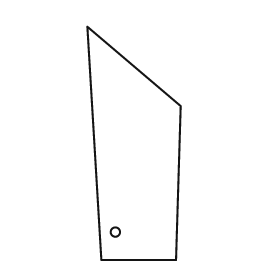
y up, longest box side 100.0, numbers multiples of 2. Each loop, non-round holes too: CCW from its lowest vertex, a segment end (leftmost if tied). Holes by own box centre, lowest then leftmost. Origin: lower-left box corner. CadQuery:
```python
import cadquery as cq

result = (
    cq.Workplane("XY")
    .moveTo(6.0, 0.0)
    .lineTo(38.0, 0.0)
    .lineTo(40.0, 66.0)
    .lineTo(0.0, 100.0)
    .close()
    .moveTo(12.0, 12.0)
    .circle(2.0)
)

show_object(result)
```